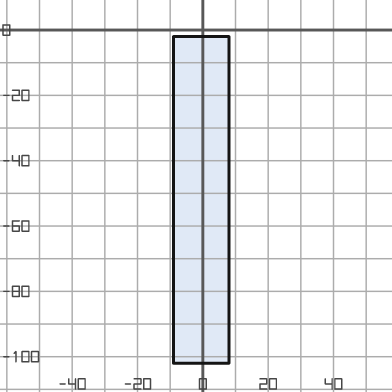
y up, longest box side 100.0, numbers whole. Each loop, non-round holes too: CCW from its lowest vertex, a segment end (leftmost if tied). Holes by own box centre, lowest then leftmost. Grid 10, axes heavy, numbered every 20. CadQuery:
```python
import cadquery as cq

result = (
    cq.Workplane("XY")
    .moveTo(-9.0, -102.0)
    .lineTo(8.0, -102.0)
    .lineTo(8.0, -2.0)
    .lineTo(-9.0, -2.0)
    .close()
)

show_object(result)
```